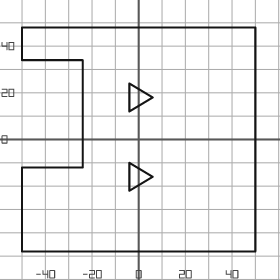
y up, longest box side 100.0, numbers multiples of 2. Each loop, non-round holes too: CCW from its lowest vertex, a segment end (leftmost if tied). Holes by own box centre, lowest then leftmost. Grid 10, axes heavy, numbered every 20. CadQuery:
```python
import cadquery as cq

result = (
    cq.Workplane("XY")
    .moveTo(-50.0, -48.0)
    .lineTo(50.0, -48.0)
    .lineTo(50.0, 48.0)
    .lineTo(-50.0, 48.0)
    .lineTo(-50.0, 34.0)
    .lineTo(-24.0, 34.0)
    .lineTo(-24.0, -12.0)
    .lineTo(-50.0, -12.0)
    .close()
    .moveTo(-4.0, -22.0)
    .lineTo(6.0, -16.0)
    .lineTo(-4.0, -10.0)
    .close()
    .moveTo(-4.0, 12.0)
    .lineTo(6.0, 18.0)
    .lineTo(-4.0, 24.0)
    .close()
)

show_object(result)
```